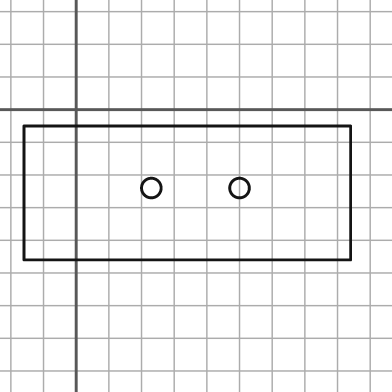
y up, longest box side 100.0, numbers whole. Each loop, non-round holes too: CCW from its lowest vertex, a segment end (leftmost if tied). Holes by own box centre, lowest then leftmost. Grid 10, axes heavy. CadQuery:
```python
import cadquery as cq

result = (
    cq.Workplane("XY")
    .moveTo(-16.0, -46.0)
    .lineTo(84.0, -46.0)
    .lineTo(84.0, -5.0)
    .lineTo(-16.0, -5.0)
    .close()
    .moveTo(23.0, -24.0)
    .circle(3.0)
    .moveTo(50.0, -24.0)
    .circle(3.0)
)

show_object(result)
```